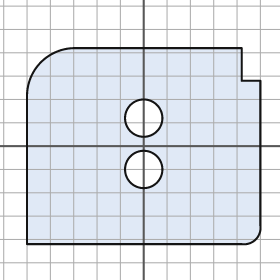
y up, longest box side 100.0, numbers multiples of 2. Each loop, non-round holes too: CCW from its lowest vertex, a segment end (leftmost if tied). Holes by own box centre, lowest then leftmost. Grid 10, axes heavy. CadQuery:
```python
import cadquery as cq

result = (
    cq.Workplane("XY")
    .moveTo(-50.0, -42.0)
    .lineTo(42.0, -42.0)
    .threePointArc((48.0, -40.0), (50.0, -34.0))
    .lineTo(50.0, 28.0)
    .lineTo(42.0, 28.0)
    .lineTo(42.0, 42.0)
    .lineTo(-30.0, 42.0)
    .threePointArc((-44.0, 36.0), (-50.0, 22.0))
    .close()
    .moveTo(0.0, -10.0)
    .circle(8.0)
    .moveTo(0.0, 12.0)
    .circle(8.0)
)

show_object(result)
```